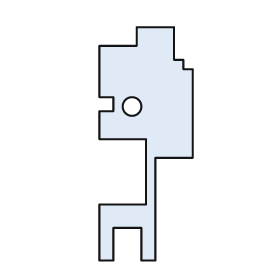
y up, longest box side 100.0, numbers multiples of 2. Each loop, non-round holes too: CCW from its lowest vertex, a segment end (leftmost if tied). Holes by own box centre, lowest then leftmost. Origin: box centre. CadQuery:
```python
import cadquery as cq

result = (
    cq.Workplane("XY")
    .moveTo(-20.0, -50.0)
    .lineTo(-14.0, -50.0)
    .lineTo(-14.0, -36.0)
    .lineTo(-2.0, -36.0)
    .lineTo(-2.0, -50.0)
    .lineTo(4.0, -50.0)
    .lineTo(4.0, -6.0)
    .lineTo(20.0, -6.0)
    .lineTo(20.0, 32.0)
    .lineTo(16.0, 32.0)
    .lineTo(16.0, 36.0)
    .lineTo(12.0, 36.0)
    .lineTo(12.0, 50.0)
    .lineTo(-4.0, 50.0)
    .lineTo(-4.0, 42.0)
    .lineTo(-20.0, 42.0)
    .lineTo(-20.0, 20.0)
    .lineTo(-14.0, 20.0)
    .lineTo(-14.0, 14.0)
    .lineTo(-20.0, 14.0)
    .lineTo(-20.0, 2.0)
    .lineTo(0.0, 2.0)
    .lineTo(0.0, -26.0)
    .lineTo(-20.0, -26.0)
    .close()
    .moveTo(-6.0, 16.0)
    .circle(4.0)
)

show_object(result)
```